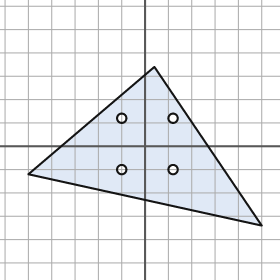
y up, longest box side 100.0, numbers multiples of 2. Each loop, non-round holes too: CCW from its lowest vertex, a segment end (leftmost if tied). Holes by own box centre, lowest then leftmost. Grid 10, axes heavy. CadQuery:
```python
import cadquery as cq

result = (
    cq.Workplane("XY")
    .moveTo(50.0, -34.0)
    .lineTo(4.0, 34.0)
    .lineTo(-50.0, -12.0)
    .close()
    .moveTo(-10.0, -10.0)
    .circle(2.0)
    .moveTo(12.0, -10.0)
    .circle(2.0)
    .moveTo(-10.0, 12.0)
    .circle(2.0)
    .moveTo(12.0, 12.0)
    .circle(2.0)
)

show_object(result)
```